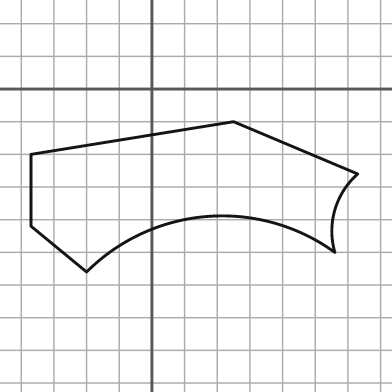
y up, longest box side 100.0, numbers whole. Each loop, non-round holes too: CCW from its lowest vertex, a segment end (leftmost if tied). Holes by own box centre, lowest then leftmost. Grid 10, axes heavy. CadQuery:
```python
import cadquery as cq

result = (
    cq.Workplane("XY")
    .moveTo(-20.0, -56.0)
    .threePointArc((17.0, -39.0), (56.0, -50.0))
    .threePointArc((56.0, -37.0), (63.0, -26.0))
    .lineTo(25.0, -10.0)
    .lineTo(-37.0, -20.0)
    .lineTo(-37.0, -42.0)
    .close()
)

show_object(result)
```